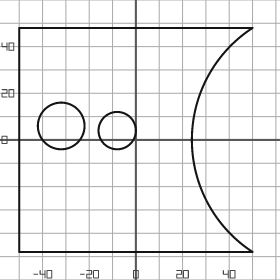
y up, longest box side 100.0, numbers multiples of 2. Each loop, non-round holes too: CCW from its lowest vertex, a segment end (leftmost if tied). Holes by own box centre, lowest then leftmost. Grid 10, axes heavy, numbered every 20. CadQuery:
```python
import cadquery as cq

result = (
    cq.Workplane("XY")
    .moveTo(-50.0, -48.0)
    .lineTo(50.0, -48.0)
    .threePointArc((24.0, 0.0), (50.0, 48.0))
    .lineTo(-50.0, 48.0)
    .close()
    .moveTo(-8.0, 4.0)
    .circle(8.0)
    .moveTo(-32.0, 6.0)
    .circle(10.0)
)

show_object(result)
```